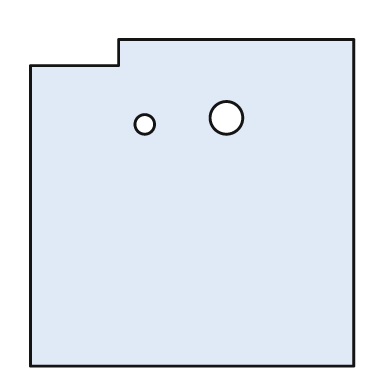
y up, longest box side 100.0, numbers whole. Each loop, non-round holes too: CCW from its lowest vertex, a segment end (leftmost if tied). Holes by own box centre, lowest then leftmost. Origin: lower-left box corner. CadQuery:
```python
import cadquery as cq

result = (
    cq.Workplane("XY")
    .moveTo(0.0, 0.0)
    .lineTo(99.0, 0.0)
    .lineTo(99.0, 100.0)
    .lineTo(27.0, 100.0)
    .lineTo(27.0, 92.0)
    .lineTo(0.0, 92.0)
    .close()
    .moveTo(35.0, 74.0)
    .circle(3.0)
    .moveTo(60.0, 76.0)
    .circle(5.0)
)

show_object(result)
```